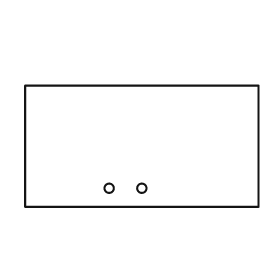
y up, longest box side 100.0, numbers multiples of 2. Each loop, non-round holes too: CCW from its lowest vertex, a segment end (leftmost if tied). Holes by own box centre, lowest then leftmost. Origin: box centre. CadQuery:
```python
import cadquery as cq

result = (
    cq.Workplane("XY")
    .moveTo(-50.0, -26.0)
    .lineTo(50.0, -26.0)
    .lineTo(50.0, 26.0)
    .lineTo(-50.0, 26.0)
    .close()
    .moveTo(-14.0, -18.0)
    .circle(2.0)
    .moveTo(0.0, -18.0)
    .circle(2.0)
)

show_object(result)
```